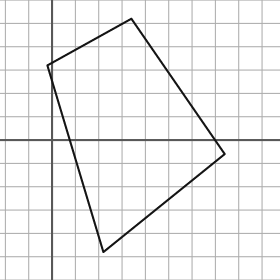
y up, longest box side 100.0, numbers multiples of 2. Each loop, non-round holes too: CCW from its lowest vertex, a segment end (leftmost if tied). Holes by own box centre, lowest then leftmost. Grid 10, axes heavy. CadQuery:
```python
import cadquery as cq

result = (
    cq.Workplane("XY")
    .moveTo(22.0, -48.0)
    .lineTo(74.0, -6.0)
    .lineTo(34.0, 52.0)
    .lineTo(-2.0, 32.0)
    .close()
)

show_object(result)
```